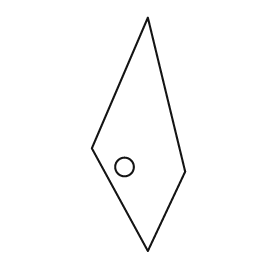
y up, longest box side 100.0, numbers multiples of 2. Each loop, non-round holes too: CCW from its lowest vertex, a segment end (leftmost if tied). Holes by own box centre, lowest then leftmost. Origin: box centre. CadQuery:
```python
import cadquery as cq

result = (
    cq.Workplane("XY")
    .moveTo(4.0, -50.0)
    .lineTo(20.0, -16.0)
    .lineTo(4.0, 50.0)
    .lineTo(-20.0, -6.0)
    .close()
    .moveTo(-6.0, -14.0)
    .circle(4.0)
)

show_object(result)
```